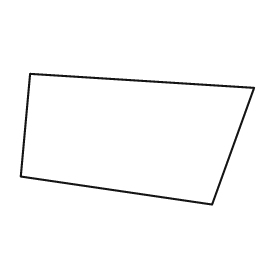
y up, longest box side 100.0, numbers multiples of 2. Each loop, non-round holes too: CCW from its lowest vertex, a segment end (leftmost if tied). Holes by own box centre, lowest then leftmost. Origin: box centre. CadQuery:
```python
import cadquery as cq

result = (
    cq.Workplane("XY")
    .moveTo(32.0, -28.0)
    .lineTo(50.0, 22.0)
    .lineTo(-46.0, 28.0)
    .lineTo(-50.0, -16.0)
    .close()
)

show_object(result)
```